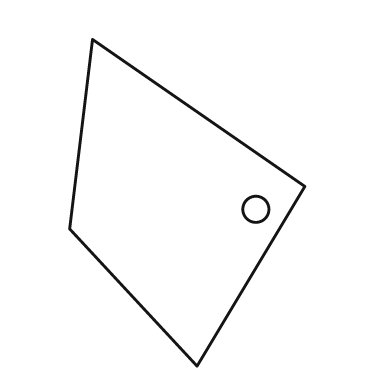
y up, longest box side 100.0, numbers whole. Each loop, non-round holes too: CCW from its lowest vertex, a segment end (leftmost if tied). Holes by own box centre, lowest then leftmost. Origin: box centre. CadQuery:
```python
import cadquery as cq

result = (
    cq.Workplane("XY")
    .moveTo(3.0, -50.0)
    .lineTo(36.0, 5.0)
    .lineTo(-29.0, 50.0)
    .lineTo(-36.0, -8.0)
    .close()
    .moveTo(21.0, -2.0)
    .circle(4.0)
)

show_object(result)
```